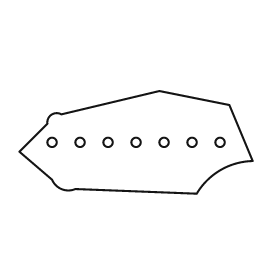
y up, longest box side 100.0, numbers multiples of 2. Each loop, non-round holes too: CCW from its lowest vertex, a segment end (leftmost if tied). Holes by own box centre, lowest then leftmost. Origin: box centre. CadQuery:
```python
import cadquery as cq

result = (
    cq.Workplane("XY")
    .moveTo(26.0, -22.0)
    .threePointArc((36.0, -12.0), (50.0, -8.0))
    .lineTo(40.0, 16.0)
    .lineTo(10.0, 22.0)
    .lineTo(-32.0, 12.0)
    .threePointArc((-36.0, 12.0), (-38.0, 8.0))
    .lineTo(-50.0, -4.0)
    .lineTo(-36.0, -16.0)
    .threePointArc((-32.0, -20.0), (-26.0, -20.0))
    .close()
    .moveTo(-36.0, 0.0)
    .circle(2.0)
    .moveTo(-24.0, 0.0)
    .circle(2.0)
    .moveTo(-12.0, 0.0)
    .circle(2.0)
    .moveTo(0.0, 0.0)
    .circle(2.0)
    .moveTo(12.0, 0.0)
    .circle(2.0)
    .moveTo(24.0, 0.0)
    .circle(2.0)
    .moveTo(36.0, 0.0)
    .circle(2.0)
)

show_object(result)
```